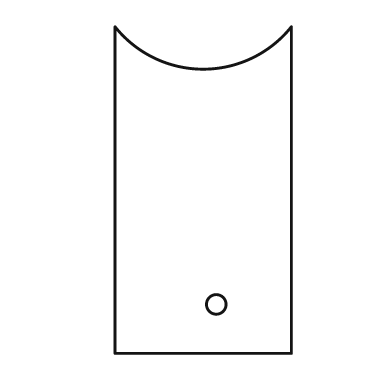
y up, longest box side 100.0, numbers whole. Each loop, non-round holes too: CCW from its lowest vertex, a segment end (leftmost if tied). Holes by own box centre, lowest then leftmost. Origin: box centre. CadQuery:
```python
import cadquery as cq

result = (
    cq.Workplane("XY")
    .moveTo(-27.0, -50.0)
    .lineTo(27.0, -50.0)
    .lineTo(27.0, 50.0)
    .threePointArc((0.0, 37.0), (-27.0, 50.0))
    .close()
    .moveTo(4.0, -35.0)
    .circle(3.0)
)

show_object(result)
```